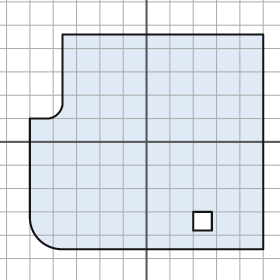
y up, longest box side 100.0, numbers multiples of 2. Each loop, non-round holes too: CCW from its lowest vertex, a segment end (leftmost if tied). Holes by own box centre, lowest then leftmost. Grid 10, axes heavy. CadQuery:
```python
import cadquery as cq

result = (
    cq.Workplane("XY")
    .moveTo(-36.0, -46.0)
    .lineTo(50.0, -46.0)
    .lineTo(50.0, 46.0)
    .lineTo(-36.0, 46.0)
    .lineTo(-36.0, 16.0)
    .threePointArc((-38.0, 12.0), (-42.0, 10.0))
    .lineTo(-50.0, 10.0)
    .lineTo(-50.0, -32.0)
    .threePointArc((-46.0, -42.0), (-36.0, -46.0))
    .close()
    .moveTo(20.0, -38.0)
    .lineTo(28.0, -38.0)
    .lineTo(28.0, -30.0)
    .lineTo(20.0, -30.0)
    .close()
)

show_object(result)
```